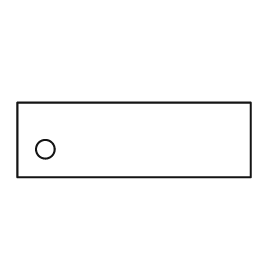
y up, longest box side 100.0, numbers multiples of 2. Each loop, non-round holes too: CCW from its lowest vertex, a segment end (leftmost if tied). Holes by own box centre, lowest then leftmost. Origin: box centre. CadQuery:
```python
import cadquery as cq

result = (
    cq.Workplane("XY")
    .moveTo(-50.0, -16.0)
    .lineTo(50.0, -16.0)
    .lineTo(50.0, 16.0)
    .lineTo(-50.0, 16.0)
    .close()
    .moveTo(-38.0, -4.0)
    .circle(4.0)
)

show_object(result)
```